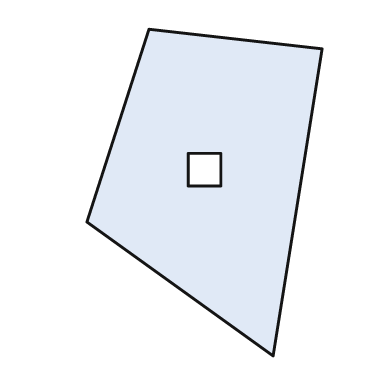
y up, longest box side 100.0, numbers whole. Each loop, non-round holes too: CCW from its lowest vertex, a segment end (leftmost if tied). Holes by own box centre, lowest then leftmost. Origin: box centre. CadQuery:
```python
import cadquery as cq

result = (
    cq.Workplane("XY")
    .moveTo(21.0, -50.0)
    .lineTo(36.0, 44.0)
    .lineTo(-17.0, 50.0)
    .lineTo(-36.0, -9.0)
    .close()
    .moveTo(-5.0, 2.0)
    .lineTo(5.0, 2.0)
    .lineTo(5.0, 12.0)
    .lineTo(-5.0, 12.0)
    .close()
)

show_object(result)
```